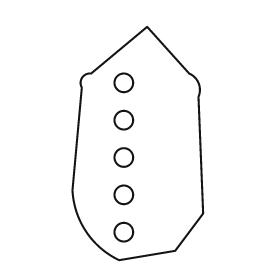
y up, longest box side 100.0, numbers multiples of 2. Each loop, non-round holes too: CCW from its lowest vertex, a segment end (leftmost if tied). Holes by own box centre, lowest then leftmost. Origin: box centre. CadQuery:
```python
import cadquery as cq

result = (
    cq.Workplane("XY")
    .moveTo(-8.0, -50.0)
    .lineTo(16.0, -46.0)
    .lineTo(28.0, -30.0)
    .lineTo(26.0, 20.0)
    .threePointArc((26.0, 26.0), (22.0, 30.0))
    .lineTo(4.0, 50.0)
    .lineTo(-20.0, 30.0)
    .threePointArc((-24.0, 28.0), (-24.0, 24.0))
    .lineTo(-28.0, -20.0)
    .threePointArc((-22.0, -38.0), (-8.0, -50.0))
    .close()
    .moveTo(-6.0, -38.0)
    .circle(4.0)
    .moveTo(-6.0, -22.0)
    .circle(4.0)
    .moveTo(-6.0, -6.0)
    .circle(4.0)
    .moveTo(-6.0, 10.0)
    .circle(4.0)
    .moveTo(-6.0, 26.0)
    .circle(4.0)
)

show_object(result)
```